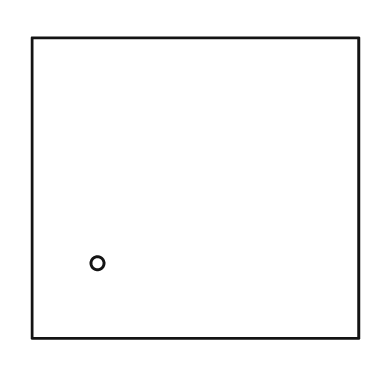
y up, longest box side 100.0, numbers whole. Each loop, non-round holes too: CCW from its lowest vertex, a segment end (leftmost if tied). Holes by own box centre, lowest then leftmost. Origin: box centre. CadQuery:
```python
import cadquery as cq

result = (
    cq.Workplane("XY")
    .moveTo(-50.0, -46.0)
    .lineTo(50.0, -46.0)
    .lineTo(50.0, 46.0)
    .lineTo(-50.0, 46.0)
    .close()
    .moveTo(-30.0, -23.0)
    .circle(2.0)
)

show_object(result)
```